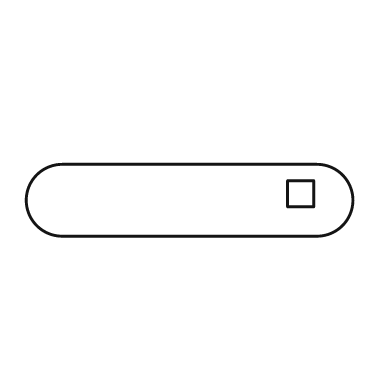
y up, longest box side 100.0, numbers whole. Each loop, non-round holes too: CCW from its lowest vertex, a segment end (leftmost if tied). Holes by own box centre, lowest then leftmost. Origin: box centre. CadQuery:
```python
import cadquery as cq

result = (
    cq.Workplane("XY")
    .moveTo(-39.0, -11.0)
    .lineTo(39.0, -11.0)
    .threePointArc((50.0, 0.0), (39.0, 11.0))
    .lineTo(-39.0, 11.0)
    .threePointArc((-50.0, 0.0), (-39.0, -11.0))
    .close()
    .moveTo(30.0, -2.0)
    .lineTo(38.0, -2.0)
    .lineTo(38.0, 6.0)
    .lineTo(30.0, 6.0)
    .close()
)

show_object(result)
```